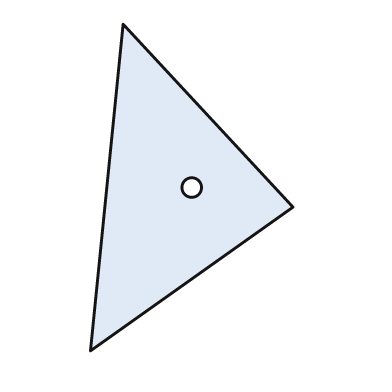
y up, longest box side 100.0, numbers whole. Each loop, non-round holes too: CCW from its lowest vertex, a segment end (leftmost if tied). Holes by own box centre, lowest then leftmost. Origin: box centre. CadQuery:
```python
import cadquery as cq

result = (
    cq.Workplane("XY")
    .moveTo(-31.0, -50.0)
    .lineTo(31.0, -6.0)
    .lineTo(-21.0, 50.0)
    .close()
    .moveTo(0.0, 0.0)
    .circle(3.0)
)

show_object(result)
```